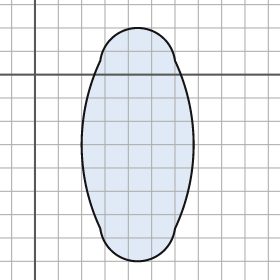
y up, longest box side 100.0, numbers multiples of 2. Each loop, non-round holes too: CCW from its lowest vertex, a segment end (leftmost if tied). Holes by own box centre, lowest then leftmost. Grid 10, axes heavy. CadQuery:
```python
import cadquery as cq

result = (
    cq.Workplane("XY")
    .moveTo(28.0, -66.0)
    .threePointArc((44.0, -80.0), (60.0, -66.0))
    .threePointArc((68.0, -30.0), (60.0, 6.0))
    .threePointArc((44.0, 20.0), (28.0, 6.0))
    .threePointArc((20.0, -30.0), (28.0, -66.0))
    .close()
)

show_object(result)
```